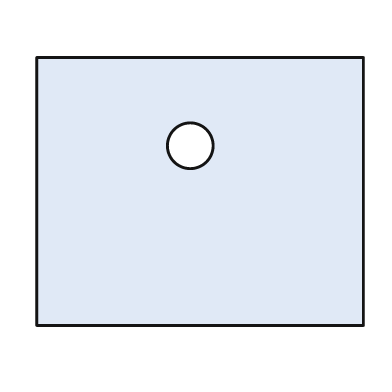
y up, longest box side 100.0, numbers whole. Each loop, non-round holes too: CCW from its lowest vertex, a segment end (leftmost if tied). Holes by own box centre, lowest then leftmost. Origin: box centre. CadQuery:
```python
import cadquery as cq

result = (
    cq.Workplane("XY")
    .moveTo(-50.0, -41.0)
    .lineTo(50.0, -41.0)
    .lineTo(50.0, 41.0)
    .lineTo(-50.0, 41.0)
    .close()
    .moveTo(-3.0, 14.0)
    .circle(7.0)
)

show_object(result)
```